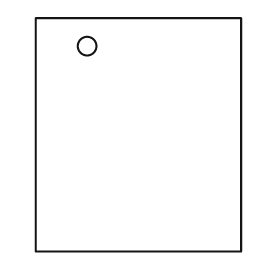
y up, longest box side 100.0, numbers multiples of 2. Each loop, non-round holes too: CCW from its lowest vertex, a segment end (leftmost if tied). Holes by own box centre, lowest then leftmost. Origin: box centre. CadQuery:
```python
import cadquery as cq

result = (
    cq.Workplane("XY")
    .moveTo(-44.0, -50.0)
    .lineTo(44.0, -50.0)
    .lineTo(44.0, 50.0)
    .lineTo(-44.0, 50.0)
    .close()
    .moveTo(-22.0, 38.0)
    .circle(4.0)
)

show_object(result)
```